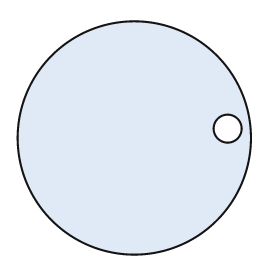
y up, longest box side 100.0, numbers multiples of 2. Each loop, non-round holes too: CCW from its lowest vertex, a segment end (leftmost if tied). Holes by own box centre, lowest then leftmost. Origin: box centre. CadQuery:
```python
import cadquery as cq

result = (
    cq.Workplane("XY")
    .moveTo(0.0, 0.0)
    .circle(50.0)
    .moveTo(40.0, 4.0)
    .circle(6.0)
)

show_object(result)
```